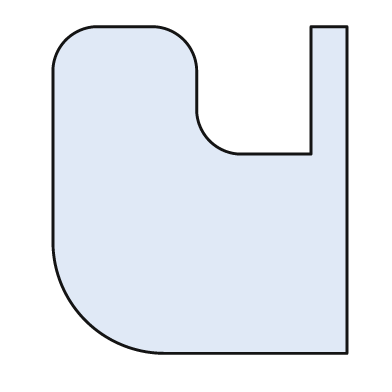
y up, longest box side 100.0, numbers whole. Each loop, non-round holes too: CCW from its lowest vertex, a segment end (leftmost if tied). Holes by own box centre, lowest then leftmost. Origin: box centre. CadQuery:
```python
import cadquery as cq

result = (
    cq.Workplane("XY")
    .moveTo(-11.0, -50.0)
    .lineTo(45.0, -50.0)
    .lineTo(45.0, 50.0)
    .lineTo(34.0, 50.0)
    .lineTo(34.0, 11.0)
    .lineTo(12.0, 11.0)
    .threePointArc((3.0, 15.0), (-1.0, 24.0))
    .lineTo(-1.0, 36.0)
    .threePointArc((-5.0, 46.0), (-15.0, 50.0))
    .lineTo(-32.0, 50.0)
    .threePointArc((-41.0, 46.0), (-45.0, 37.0))
    .lineTo(-45.0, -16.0)
    .threePointArc((-35.0, -40.0), (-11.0, -50.0))
    .close()
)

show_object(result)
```